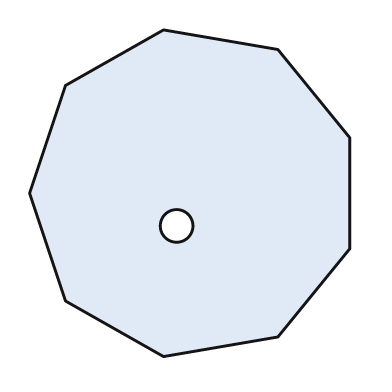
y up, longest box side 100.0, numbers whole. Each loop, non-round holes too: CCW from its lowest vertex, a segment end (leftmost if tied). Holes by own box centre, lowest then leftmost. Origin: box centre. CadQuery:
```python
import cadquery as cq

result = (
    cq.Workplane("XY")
    .moveTo(-8.0, -50.0)
    .lineTo(27.0, -44.0)
    .lineTo(49.0, -17.0)
    .lineTo(49.0, 17.0)
    .lineTo(27.0, 44.0)
    .lineTo(-8.0, 50.0)
    .lineTo(-38.0, 33.0)
    .lineTo(-49.0, 0.0)
    .lineTo(-38.0, -33.0)
    .close()
    .moveTo(-4.0, -10.0)
    .circle(5.0)
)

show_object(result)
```